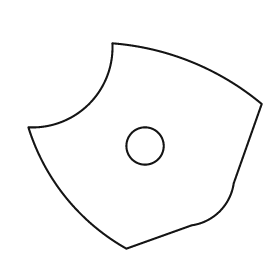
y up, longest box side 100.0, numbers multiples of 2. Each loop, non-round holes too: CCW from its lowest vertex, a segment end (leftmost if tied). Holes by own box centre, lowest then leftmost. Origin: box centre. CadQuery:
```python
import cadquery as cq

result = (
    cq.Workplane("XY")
    .moveTo(-8.0, -44.0)
    .lineTo(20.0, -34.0)
    .threePointArc((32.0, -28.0), (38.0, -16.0))
    .lineTo(50.0, 18.0)
    .threePointArc((20.0, 36.0), (-14.0, 44.0))
    .threePointArc((-24.0, 18.0), (-50.0, 8.0))
    .threePointArc((-34.0, -22.0), (-8.0, -44.0))
    .close()
    .moveTo(0.0, 0.0)
    .circle(8.0)
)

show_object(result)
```